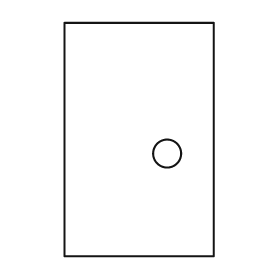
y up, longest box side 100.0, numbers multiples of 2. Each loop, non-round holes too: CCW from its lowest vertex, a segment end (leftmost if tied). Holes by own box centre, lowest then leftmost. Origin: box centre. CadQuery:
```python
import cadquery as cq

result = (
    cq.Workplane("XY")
    .moveTo(-32.0, -50.0)
    .lineTo(32.0, -50.0)
    .lineTo(32.0, 50.0)
    .lineTo(-32.0, 50.0)
    .close()
    .moveTo(12.0, -6.0)
    .circle(6.0)
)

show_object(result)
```